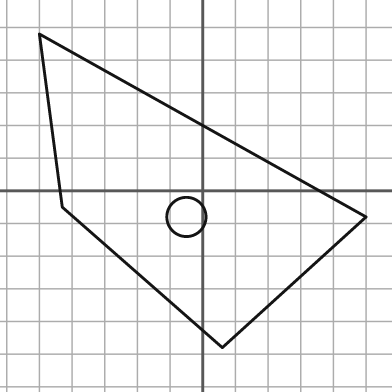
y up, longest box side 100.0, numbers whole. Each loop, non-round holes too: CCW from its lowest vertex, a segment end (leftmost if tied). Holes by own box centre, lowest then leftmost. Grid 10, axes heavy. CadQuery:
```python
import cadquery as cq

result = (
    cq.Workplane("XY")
    .moveTo(6.0, -48.0)
    .lineTo(50.0, -8.0)
    .lineTo(-50.0, 48.0)
    .lineTo(-43.0, -5.0)
    .close()
    .moveTo(-5.0, -8.0)
    .circle(6.0)
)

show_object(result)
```